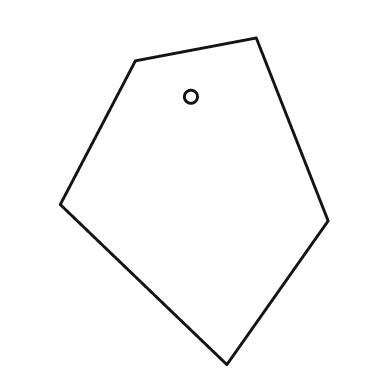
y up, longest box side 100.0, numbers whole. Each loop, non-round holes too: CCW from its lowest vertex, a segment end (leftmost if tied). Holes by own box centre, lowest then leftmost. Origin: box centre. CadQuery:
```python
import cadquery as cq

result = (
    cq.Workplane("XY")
    .moveTo(10.0, -50.0)
    .lineTo(41.0, -6.0)
    .lineTo(19.0, 50.0)
    .lineTo(-18.0, 43.0)
    .lineTo(-41.0, -1.0)
    .close()
    .moveTo(-1.0, 32.0)
    .circle(2.0)
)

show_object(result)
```